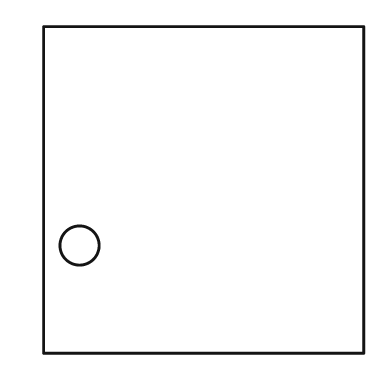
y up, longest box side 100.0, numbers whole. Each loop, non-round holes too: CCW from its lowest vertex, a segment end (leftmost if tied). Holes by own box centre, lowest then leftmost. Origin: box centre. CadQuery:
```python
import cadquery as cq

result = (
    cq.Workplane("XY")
    .moveTo(-49.0, -50.0)
    .lineTo(49.0, -50.0)
    .lineTo(49.0, 50.0)
    .lineTo(-49.0, 50.0)
    .close()
    .moveTo(-38.0, -17.0)
    .circle(6.0)
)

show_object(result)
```